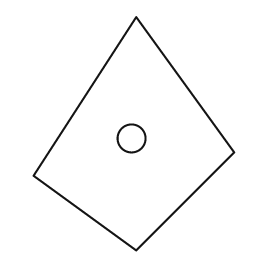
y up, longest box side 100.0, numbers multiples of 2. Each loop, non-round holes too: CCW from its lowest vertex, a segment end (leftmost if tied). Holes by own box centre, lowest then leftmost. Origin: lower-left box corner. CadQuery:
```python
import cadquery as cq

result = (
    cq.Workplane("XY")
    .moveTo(44.0, 0.0)
    .lineTo(86.0, 42.0)
    .lineTo(44.0, 100.0)
    .lineTo(0.0, 32.0)
    .close()
    .moveTo(42.0, 48.0)
    .circle(6.0)
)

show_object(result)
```